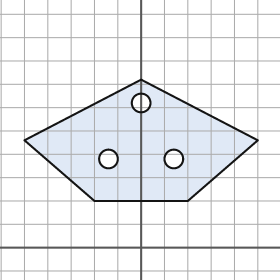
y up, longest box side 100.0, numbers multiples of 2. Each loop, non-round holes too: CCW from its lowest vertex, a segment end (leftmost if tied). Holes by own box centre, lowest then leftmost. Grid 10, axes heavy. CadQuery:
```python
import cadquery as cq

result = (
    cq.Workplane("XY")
    .moveTo(-20.0, 20.0)
    .lineTo(20.0, 20.0)
    .lineTo(50.0, 46.0)
    .lineTo(0.0, 72.0)
    .lineTo(-50.0, 46.0)
    .close()
    .moveTo(-14.0, 38.0)
    .circle(4.0)
    .moveTo(14.0, 38.0)
    .circle(4.0)
    .moveTo(0.0, 62.0)
    .circle(4.0)
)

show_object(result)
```